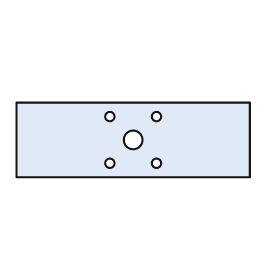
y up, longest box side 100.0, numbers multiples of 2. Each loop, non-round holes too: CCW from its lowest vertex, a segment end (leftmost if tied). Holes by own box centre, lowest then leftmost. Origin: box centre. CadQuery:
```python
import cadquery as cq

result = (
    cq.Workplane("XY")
    .moveTo(-50.0, -16.0)
    .lineTo(50.0, -16.0)
    .lineTo(50.0, 16.0)
    .lineTo(-50.0, 16.0)
    .close()
    .moveTo(-10.0, -10.0)
    .circle(2.0)
    .moveTo(10.0, -10.0)
    .circle(2.0)
    .moveTo(0.0, 0.0)
    .circle(4.0)
    .moveTo(-10.0, 10.0)
    .circle(2.0)
    .moveTo(10.0, 10.0)
    .circle(2.0)
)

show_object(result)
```